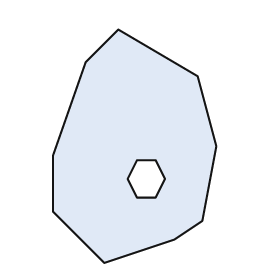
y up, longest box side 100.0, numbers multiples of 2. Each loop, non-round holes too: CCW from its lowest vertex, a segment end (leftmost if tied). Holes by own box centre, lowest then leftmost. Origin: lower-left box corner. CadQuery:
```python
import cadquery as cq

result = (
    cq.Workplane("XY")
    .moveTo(22.0, 0.0)
    .lineTo(52.0, 10.0)
    .lineTo(64.0, 18.0)
    .lineTo(70.0, 50.0)
    .lineTo(62.0, 80.0)
    .lineTo(28.0, 100.0)
    .lineTo(14.0, 86.0)
    .lineTo(0.0, 46.0)
    .lineTo(0.0, 22.0)
    .close()
    .moveTo(36.0, 28.0)
    .lineTo(44.0, 28.0)
    .lineTo(48.0, 36.0)
    .lineTo(44.0, 44.0)
    .lineTo(36.0, 44.0)
    .lineTo(32.0, 36.0)
    .close()
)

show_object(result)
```